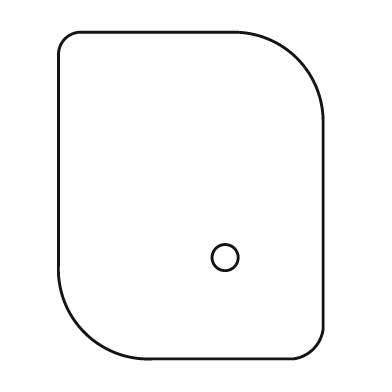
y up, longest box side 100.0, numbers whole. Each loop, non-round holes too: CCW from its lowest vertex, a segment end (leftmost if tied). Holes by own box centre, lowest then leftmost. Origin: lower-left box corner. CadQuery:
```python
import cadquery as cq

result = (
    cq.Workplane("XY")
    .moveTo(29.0, 0.0)
    .lineTo(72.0, 0.0)
    .threePointArc((78.0, 3.0), (81.0, 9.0))
    .lineTo(81.0, 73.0)
    .threePointArc((73.0, 92.0), (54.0, 100.0))
    .lineTo(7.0, 100.0)
    .threePointArc((2.0, 98.0), (0.0, 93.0))
    .lineTo(0.0, 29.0)
    .threePointArc((8.0, 8.0), (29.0, 0.0))
    .close()
    .moveTo(51.0, 31.0)
    .circle(4.0)
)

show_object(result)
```